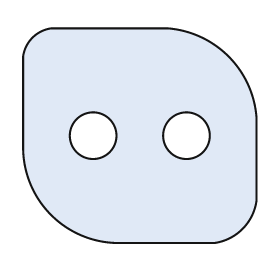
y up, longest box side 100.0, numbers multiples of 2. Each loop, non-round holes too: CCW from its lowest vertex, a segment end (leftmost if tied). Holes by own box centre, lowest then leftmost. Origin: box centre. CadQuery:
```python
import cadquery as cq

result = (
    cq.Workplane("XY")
    .moveTo(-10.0, -46.0)
    .lineTo(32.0, -46.0)
    .threePointArc((44.0, -40.0), (50.0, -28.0))
    .lineTo(50.0, 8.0)
    .threePointArc((38.0, 34.0), (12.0, 46.0))
    .lineTo(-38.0, 46.0)
    .threePointArc((-46.0, 42.0), (-50.0, 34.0))
    .lineTo(-50.0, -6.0)
    .threePointArc((-38.0, -34.0), (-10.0, -46.0))
    .close()
    .moveTo(-20.0, 0.0)
    .circle(10.0)
    .moveTo(20.0, 0.0)
    .circle(10.0)
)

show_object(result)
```